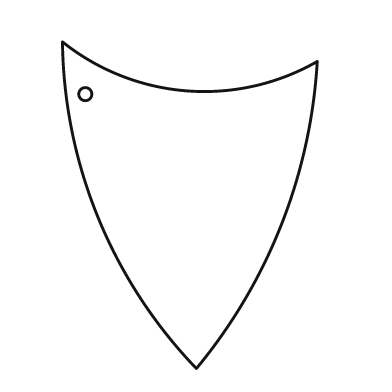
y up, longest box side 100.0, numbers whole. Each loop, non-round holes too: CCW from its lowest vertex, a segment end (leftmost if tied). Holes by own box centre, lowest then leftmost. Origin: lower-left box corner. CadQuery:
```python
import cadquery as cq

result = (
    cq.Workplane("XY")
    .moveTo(41.0, 0.0)
    .threePointArc((67.0, 44.0), (78.0, 94.0))
    .threePointArc((38.0, 85.0), (0.0, 100.0))
    .threePointArc((11.0, 46.0), (41.0, 0.0))
    .close()
    .moveTo(7.0, 84.0)
    .circle(2.0)
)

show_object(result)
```